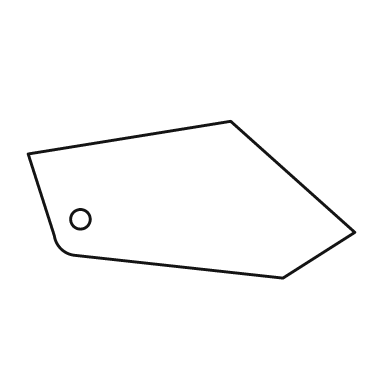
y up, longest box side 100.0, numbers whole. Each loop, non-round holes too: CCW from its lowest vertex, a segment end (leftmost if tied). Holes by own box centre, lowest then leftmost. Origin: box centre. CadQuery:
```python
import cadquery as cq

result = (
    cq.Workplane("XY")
    .moveTo(28.0, -24.0)
    .lineTo(50.0, -10.0)
    .lineTo(12.0, 24.0)
    .lineTo(-50.0, 14.0)
    .lineTo(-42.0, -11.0)
    .threePointArc((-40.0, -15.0), (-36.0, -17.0))
    .close()
    .moveTo(-34.0, -6.0)
    .circle(3.0)
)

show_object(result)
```